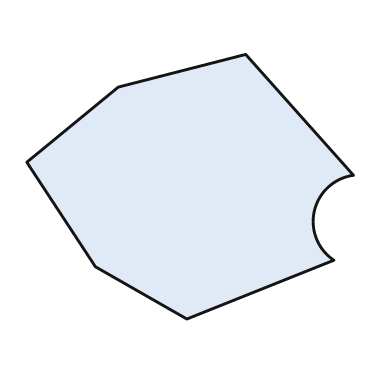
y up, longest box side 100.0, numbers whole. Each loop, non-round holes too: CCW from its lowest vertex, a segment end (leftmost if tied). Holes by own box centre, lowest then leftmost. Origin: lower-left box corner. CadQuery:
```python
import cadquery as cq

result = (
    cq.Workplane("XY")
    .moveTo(49.0, 0.0)
    .lineTo(94.0, 18.0)
    .threePointArc((88.0, 33.0), (100.0, 44.0))
    .lineTo(67.0, 81.0)
    .lineTo(28.0, 71.0)
    .lineTo(0.0, 48.0)
    .lineTo(21.0, 16.0)
    .close()
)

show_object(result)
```